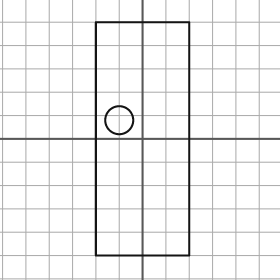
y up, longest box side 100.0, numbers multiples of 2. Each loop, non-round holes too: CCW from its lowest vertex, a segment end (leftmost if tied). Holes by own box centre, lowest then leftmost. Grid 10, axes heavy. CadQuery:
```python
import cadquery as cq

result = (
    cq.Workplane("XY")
    .moveTo(-20.0, -50.0)
    .lineTo(20.0, -50.0)
    .lineTo(20.0, 50.0)
    .lineTo(-20.0, 50.0)
    .close()
    .moveTo(-10.0, 8.0)
    .circle(6.0)
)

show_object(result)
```